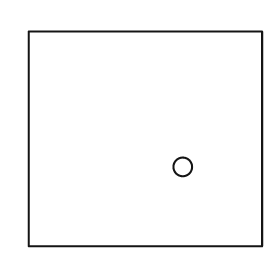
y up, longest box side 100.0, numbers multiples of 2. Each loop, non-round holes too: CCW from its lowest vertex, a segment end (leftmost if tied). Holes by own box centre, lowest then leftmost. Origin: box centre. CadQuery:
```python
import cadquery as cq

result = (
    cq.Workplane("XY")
    .moveTo(-50.0, -46.0)
    .lineTo(50.0, -46.0)
    .lineTo(50.0, 46.0)
    .lineTo(-50.0, 46.0)
    .close()
    .moveTo(16.0, -12.0)
    .circle(4.0)
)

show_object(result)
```